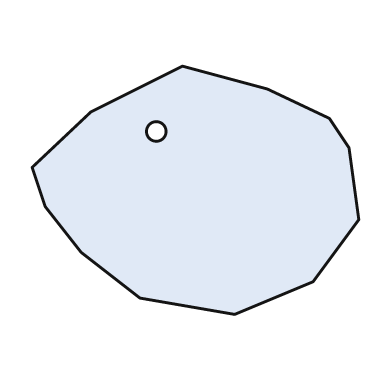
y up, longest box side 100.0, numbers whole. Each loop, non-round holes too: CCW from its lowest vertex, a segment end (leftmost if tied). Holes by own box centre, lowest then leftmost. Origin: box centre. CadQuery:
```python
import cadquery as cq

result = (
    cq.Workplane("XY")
    .moveTo(12.0, -38.0)
    .lineTo(36.0, -28.0)
    .lineTo(50.0, -9.0)
    .lineTo(47.0, 13.0)
    .lineTo(41.0, 22.0)
    .lineTo(22.0, 31.0)
    .lineTo(-4.0, 38.0)
    .lineTo(-32.0, 24.0)
    .lineTo(-50.0, 7.0)
    .lineTo(-46.0, -5.0)
    .lineTo(-35.0, -19.0)
    .lineTo(-17.0, -33.0)
    .close()
    .moveTo(-12.0, 18.0)
    .circle(3.0)
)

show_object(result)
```